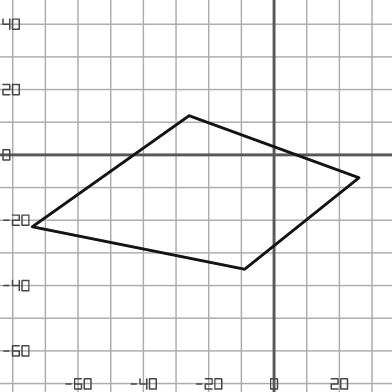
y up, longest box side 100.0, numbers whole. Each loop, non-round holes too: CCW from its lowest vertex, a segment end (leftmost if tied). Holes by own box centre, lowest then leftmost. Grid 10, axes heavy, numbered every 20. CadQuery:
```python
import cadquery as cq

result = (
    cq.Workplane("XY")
    .moveTo(-9.0, -35.0)
    .lineTo(26.0, -7.0)
    .lineTo(-26.0, 12.0)
    .lineTo(-74.0, -22.0)
    .close()
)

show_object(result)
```